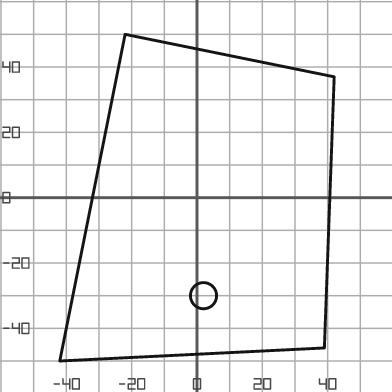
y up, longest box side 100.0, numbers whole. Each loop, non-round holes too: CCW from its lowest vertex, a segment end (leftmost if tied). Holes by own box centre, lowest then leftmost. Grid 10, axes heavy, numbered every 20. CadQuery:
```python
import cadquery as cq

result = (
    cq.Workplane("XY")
    .moveTo(-42.0, -50.0)
    .lineTo(39.0, -46.0)
    .lineTo(42.0, 37.0)
    .lineTo(-22.0, 50.0)
    .close()
    .moveTo(2.0, -30.0)
    .circle(4.0)
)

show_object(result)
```